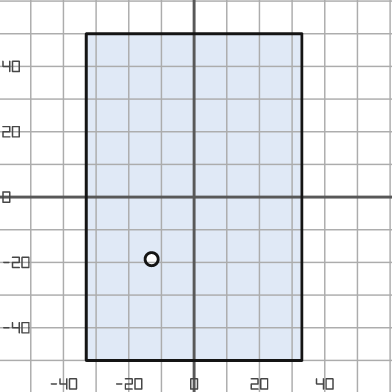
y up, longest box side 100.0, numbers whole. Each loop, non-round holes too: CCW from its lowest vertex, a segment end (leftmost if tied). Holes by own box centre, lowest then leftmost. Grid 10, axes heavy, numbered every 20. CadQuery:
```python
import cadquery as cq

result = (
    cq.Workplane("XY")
    .moveTo(-33.0, -50.0)
    .lineTo(33.0, -50.0)
    .lineTo(33.0, 50.0)
    .lineTo(-33.0, 50.0)
    .close()
    .moveTo(-13.0, -19.0)
    .circle(2.0)
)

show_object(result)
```